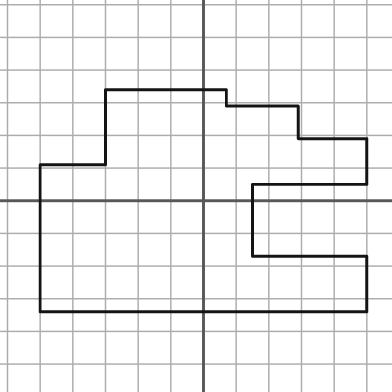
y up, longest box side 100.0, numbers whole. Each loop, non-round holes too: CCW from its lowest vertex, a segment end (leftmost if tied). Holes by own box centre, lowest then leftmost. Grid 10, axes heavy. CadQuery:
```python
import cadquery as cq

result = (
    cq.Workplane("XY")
    .moveTo(-50.0, -34.0)
    .lineTo(50.0, -34.0)
    .lineTo(50.0, -17.0)
    .lineTo(15.0, -17.0)
    .lineTo(15.0, 5.0)
    .lineTo(50.0, 5.0)
    .lineTo(50.0, 19.0)
    .lineTo(29.0, 19.0)
    .lineTo(29.0, 29.0)
    .lineTo(7.0, 29.0)
    .lineTo(7.0, 34.0)
    .lineTo(-30.0, 34.0)
    .lineTo(-30.0, 11.0)
    .lineTo(-50.0, 11.0)
    .close()
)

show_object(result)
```